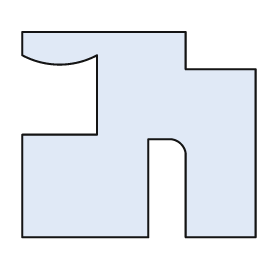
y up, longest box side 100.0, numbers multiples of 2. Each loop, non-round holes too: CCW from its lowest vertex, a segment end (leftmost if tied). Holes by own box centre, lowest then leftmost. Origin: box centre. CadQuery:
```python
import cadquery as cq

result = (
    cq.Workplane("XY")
    .moveTo(-50.0, -44.0)
    .lineTo(4.0, -44.0)
    .lineTo(4.0, -2.0)
    .lineTo(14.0, -2.0)
    .threePointArc((18.0, -4.0), (20.0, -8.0))
    .lineTo(20.0, -44.0)
    .lineTo(50.0, -44.0)
    .lineTo(50.0, 28.0)
    .lineTo(20.0, 28.0)
    .lineTo(20.0, 44.0)
    .lineTo(-50.0, 44.0)
    .lineTo(-50.0, 34.0)
    .threePointArc((-34.0, 30.0), (-18.0, 34.0))
    .lineTo(-18.0, 0.0)
    .lineTo(-50.0, 0.0)
    .close()
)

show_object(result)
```